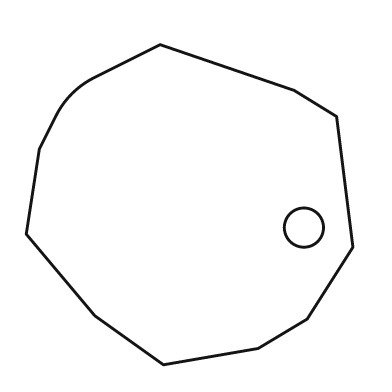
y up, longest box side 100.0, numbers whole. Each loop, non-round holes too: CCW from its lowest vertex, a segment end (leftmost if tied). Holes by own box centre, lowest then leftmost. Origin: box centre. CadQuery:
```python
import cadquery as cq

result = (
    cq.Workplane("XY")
    .moveTo(-8.0, -49.0)
    .lineTo(21.0, -44.0)
    .lineTo(36.0, -35.0)
    .lineTo(50.0, -13.0)
    .lineTo(45.0, 27.0)
    .lineTo(32.0, 35.0)
    .lineTo(-9.0, 49.0)
    .lineTo(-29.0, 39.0)
    .threePointArc((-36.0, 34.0), (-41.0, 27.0))
    .lineTo(-46.0, 17.0)
    .lineTo(-50.0, -9.0)
    .lineTo(-29.0, -34.0)
    .close()
    .moveTo(35.0, -7.0)
    .circle(6.0)
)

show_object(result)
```